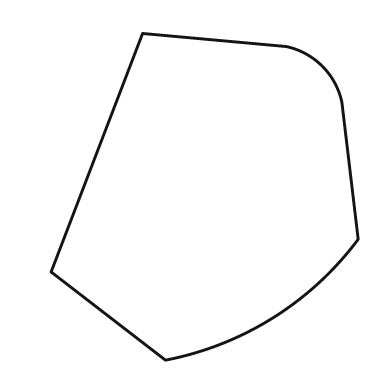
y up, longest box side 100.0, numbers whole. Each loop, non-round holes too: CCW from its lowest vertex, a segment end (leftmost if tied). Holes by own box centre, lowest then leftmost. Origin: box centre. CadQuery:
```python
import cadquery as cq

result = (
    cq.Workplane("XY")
    .moveTo(-12.0, -50.0)
    .threePointArc((21.0, -37.0), (47.0, -13.0))
    .lineTo(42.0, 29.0)
    .threePointArc((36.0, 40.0), (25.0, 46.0))
    .lineTo(-19.0, 50.0)
    .lineTo(-47.0, -23.0)
    .close()
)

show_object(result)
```